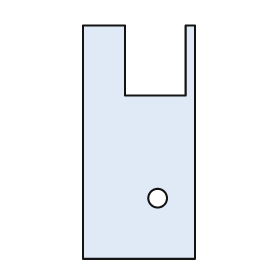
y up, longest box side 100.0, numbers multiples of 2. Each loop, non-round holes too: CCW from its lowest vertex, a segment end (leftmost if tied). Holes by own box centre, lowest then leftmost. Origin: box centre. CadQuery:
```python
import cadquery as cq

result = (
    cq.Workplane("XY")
    .moveTo(-24.0, -50.0)
    .lineTo(24.0, -50.0)
    .lineTo(24.0, 50.0)
    .lineTo(20.0, 50.0)
    .lineTo(20.0, 20.0)
    .lineTo(-6.0, 20.0)
    .lineTo(-6.0, 50.0)
    .lineTo(-24.0, 50.0)
    .close()
    .moveTo(8.0, -24.0)
    .circle(4.0)
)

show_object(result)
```